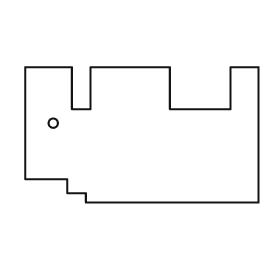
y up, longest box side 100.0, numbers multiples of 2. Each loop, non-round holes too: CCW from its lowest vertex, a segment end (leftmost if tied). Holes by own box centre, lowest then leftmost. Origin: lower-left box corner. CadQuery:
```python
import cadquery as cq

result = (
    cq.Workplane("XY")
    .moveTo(26.0, 0.0)
    .lineTo(100.0, 0.0)
    .lineTo(100.0, 58.0)
    .lineTo(88.0, 58.0)
    .lineTo(88.0, 40.0)
    .lineTo(62.0, 40.0)
    .lineTo(62.0, 58.0)
    .lineTo(28.0, 58.0)
    .lineTo(28.0, 40.0)
    .lineTo(20.0, 40.0)
    .lineTo(20.0, 58.0)
    .lineTo(0.0, 58.0)
    .lineTo(0.0, 10.0)
    .lineTo(18.0, 10.0)
    .lineTo(18.0, 4.0)
    .lineTo(26.0, 4.0)
    .close()
    .moveTo(12.0, 34.0)
    .circle(2.0)
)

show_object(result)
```